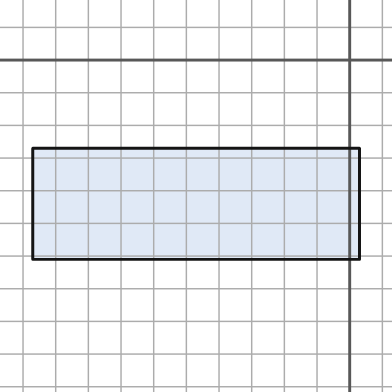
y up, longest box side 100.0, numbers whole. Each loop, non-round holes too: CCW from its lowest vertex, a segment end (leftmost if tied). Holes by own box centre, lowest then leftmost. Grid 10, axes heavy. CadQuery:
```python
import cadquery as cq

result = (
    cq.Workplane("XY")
    .moveTo(-97.0, -61.0)
    .lineTo(3.0, -61.0)
    .lineTo(3.0, -27.0)
    .lineTo(-97.0, -27.0)
    .close()
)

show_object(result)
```